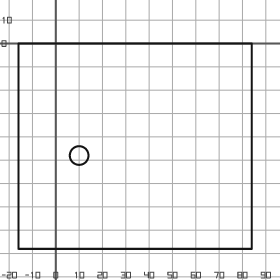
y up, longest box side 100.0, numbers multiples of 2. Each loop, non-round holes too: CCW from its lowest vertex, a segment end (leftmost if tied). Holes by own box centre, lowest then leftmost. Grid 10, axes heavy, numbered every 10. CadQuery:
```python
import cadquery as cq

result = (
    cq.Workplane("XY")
    .moveTo(-16.0, -88.0)
    .lineTo(84.0, -88.0)
    .lineTo(84.0, 0.0)
    .lineTo(-16.0, 0.0)
    .close()
    .moveTo(10.0, -48.0)
    .circle(4.0)
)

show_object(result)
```